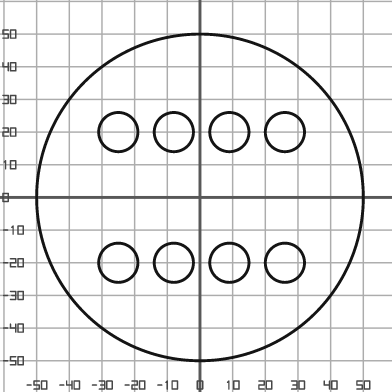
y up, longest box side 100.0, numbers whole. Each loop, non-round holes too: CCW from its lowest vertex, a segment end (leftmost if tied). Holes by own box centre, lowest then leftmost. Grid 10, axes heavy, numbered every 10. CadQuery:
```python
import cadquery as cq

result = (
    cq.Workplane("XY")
    .moveTo(0.0, 0.0)
    .circle(50.0)
    .moveTo(-25.0, -20.0)
    .circle(6.0)
    .moveTo(-8.0, -20.0)
    .circle(6.0)
    .moveTo(9.0, -20.0)
    .circle(6.0)
    .moveTo(26.0, -20.0)
    .circle(6.0)
    .moveTo(-25.0, 20.0)
    .circle(6.0)
    .moveTo(-8.0, 20.0)
    .circle(6.0)
    .moveTo(9.0, 20.0)
    .circle(6.0)
    .moveTo(26.0, 20.0)
    .circle(6.0)
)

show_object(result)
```